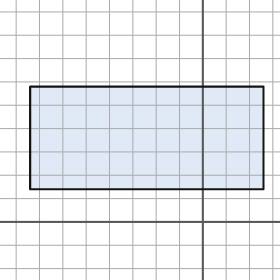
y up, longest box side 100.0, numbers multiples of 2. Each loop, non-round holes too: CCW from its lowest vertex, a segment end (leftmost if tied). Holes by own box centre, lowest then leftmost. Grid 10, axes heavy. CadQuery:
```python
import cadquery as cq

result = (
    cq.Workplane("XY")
    .moveTo(-74.0, 14.0)
    .lineTo(26.0, 14.0)
    .lineTo(26.0, 58.0)
    .lineTo(-74.0, 58.0)
    .close()
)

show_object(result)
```